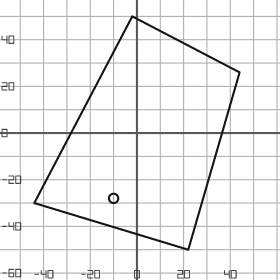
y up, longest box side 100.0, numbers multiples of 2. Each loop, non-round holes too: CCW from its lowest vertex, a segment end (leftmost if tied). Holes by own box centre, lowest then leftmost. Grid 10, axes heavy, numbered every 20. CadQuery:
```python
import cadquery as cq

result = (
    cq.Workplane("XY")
    .moveTo(22.0, -50.0)
    .lineTo(44.0, 26.0)
    .lineTo(-2.0, 50.0)
    .lineTo(-44.0, -30.0)
    .close()
    .moveTo(-10.0, -28.0)
    .circle(2.0)
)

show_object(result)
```